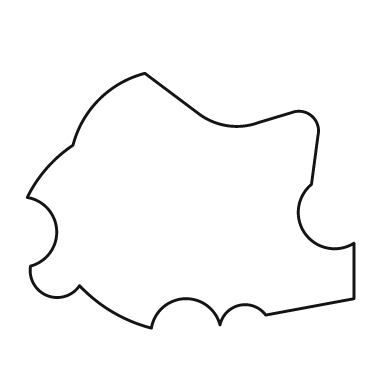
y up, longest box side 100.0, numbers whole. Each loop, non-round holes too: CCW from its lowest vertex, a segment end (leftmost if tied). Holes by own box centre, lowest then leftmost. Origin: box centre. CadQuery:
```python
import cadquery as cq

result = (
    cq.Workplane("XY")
    .moveTo(-12.0, -39.0)
    .threePointArc((-2.0, -30.0), (9.0, -38.0))
    .threePointArc((15.0, -32.0), (23.0, -35.0))
    .lineTo(50.0, -30.0)
    .lineTo(50.0, -13.0)
    .threePointArc((35.0, -10.0), (37.0, 5.0))
    .lineTo(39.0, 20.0)
    .threePointArc((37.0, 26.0), (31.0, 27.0))
    .lineTo(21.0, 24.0)
    .threePointArc((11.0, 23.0), (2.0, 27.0))
    .lineTo(-14.0, 39.0)
    .threePointArc((-28.0, 31.0), (-36.0, 17.0))
    .threePointArc((-44.0, 10.0), (-50.0, 1.0))
    .threePointArc((-41.0, -9.0), (-49.0, -20.0))
    .threePointArc((-44.0, -29.0), (-34.0, -26.0))
    .threePointArc((-24.0, -34.0), (-12.0, -39.0))
    .close()
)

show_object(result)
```